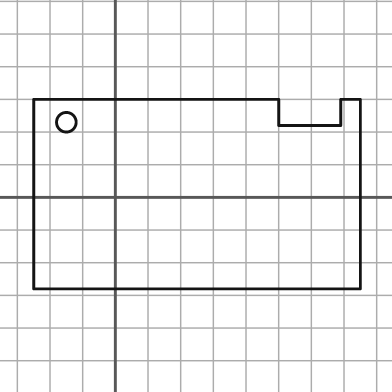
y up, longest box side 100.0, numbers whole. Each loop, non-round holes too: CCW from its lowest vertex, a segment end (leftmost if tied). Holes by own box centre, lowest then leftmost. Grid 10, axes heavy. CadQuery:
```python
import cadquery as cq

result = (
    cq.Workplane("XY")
    .moveTo(-25.0, -28.0)
    .lineTo(75.0, -28.0)
    .lineTo(75.0, 30.0)
    .lineTo(69.0, 30.0)
    .lineTo(69.0, 22.0)
    .lineTo(50.0, 22.0)
    .lineTo(50.0, 30.0)
    .lineTo(-25.0, 30.0)
    .close()
    .moveTo(-15.0, 23.0)
    .circle(3.0)
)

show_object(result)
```